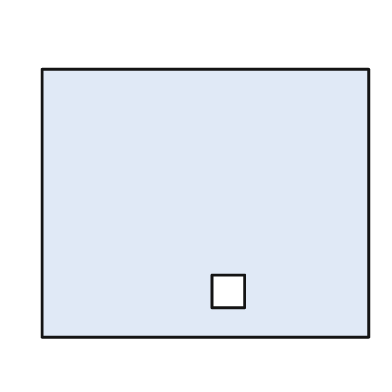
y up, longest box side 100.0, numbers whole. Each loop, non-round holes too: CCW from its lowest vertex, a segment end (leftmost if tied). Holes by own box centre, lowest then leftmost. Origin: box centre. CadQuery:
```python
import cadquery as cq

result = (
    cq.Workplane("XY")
    .moveTo(-50.0, -41.0)
    .lineTo(50.0, -41.0)
    .lineTo(50.0, 41.0)
    .lineTo(-50.0, 41.0)
    .close()
    .moveTo(2.0, -32.0)
    .lineTo(12.0, -32.0)
    .lineTo(12.0, -22.0)
    .lineTo(2.0, -22.0)
    .close()
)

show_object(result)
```